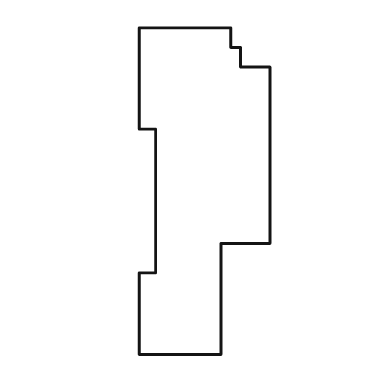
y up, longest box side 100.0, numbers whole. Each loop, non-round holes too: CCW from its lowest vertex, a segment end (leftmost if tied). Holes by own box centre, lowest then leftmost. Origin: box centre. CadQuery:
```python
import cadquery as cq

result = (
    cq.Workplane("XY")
    .moveTo(-20.0, -50.0)
    .lineTo(5.0, -50.0)
    .lineTo(5.0, -16.0)
    .lineTo(20.0, -16.0)
    .lineTo(20.0, 38.0)
    .lineTo(11.0, 38.0)
    .lineTo(11.0, 44.0)
    .lineTo(8.0, 44.0)
    .lineTo(8.0, 50.0)
    .lineTo(-20.0, 50.0)
    .lineTo(-20.0, 19.0)
    .lineTo(-15.0, 19.0)
    .lineTo(-15.0, -25.0)
    .lineTo(-20.0, -25.0)
    .close()
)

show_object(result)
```